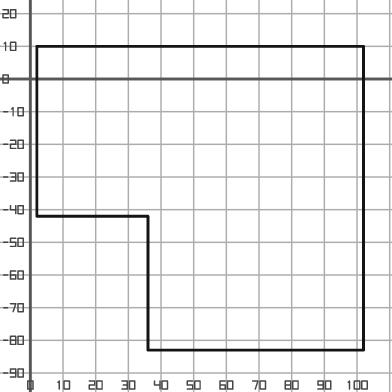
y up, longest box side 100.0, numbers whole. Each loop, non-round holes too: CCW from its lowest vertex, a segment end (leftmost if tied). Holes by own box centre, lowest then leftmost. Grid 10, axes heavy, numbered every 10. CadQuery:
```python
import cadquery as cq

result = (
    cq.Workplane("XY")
    .moveTo(36.0, -83.0)
    .lineTo(102.0, -83.0)
    .lineTo(102.0, 10.0)
    .lineTo(2.0, 10.0)
    .lineTo(2.0, -42.0)
    .lineTo(36.0, -42.0)
    .close()
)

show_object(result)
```